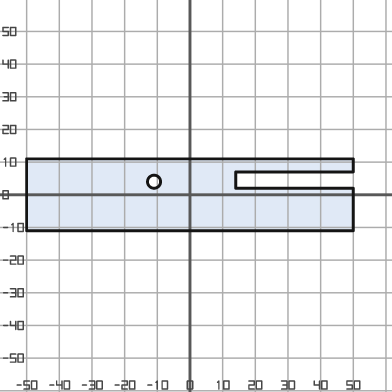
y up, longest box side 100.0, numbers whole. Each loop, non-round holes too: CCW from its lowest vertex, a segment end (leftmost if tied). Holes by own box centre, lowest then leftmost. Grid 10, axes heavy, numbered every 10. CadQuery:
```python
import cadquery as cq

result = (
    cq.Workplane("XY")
    .moveTo(-50.0, -11.0)
    .lineTo(50.0, -11.0)
    .lineTo(50.0, 2.0)
    .lineTo(14.0, 2.0)
    .lineTo(14.0, 7.0)
    .lineTo(50.0, 7.0)
    .lineTo(50.0, 11.0)
    .lineTo(-50.0, 11.0)
    .close()
    .moveTo(-11.0, 4.0)
    .circle(2.0)
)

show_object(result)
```